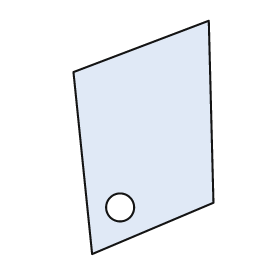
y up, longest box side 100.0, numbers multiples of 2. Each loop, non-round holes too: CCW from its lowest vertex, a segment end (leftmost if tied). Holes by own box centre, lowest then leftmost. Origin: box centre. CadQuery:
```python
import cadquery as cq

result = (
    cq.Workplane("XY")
    .moveTo(-22.0, -50.0)
    .lineTo(30.0, -28.0)
    .lineTo(28.0, 50.0)
    .lineTo(-30.0, 28.0)
    .close()
    .moveTo(-10.0, -30.0)
    .circle(6.0)
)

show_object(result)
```